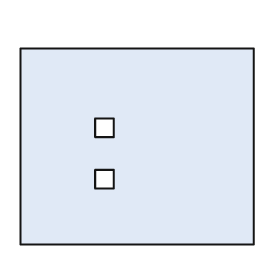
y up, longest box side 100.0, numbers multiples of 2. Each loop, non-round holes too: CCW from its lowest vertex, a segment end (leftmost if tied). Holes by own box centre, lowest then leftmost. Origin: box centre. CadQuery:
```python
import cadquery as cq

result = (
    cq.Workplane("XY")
    .moveTo(-50.0, -42.0)
    .lineTo(50.0, -42.0)
    .lineTo(50.0, 42.0)
    .lineTo(-50.0, 42.0)
    .close()
    .moveTo(-18.0, -18.0)
    .lineTo(-10.0, -18.0)
    .lineTo(-10.0, -10.0)
    .lineTo(-18.0, -10.0)
    .close()
    .moveTo(-18.0, 4.0)
    .lineTo(-10.0, 4.0)
    .lineTo(-10.0, 12.0)
    .lineTo(-18.0, 12.0)
    .close()
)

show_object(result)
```